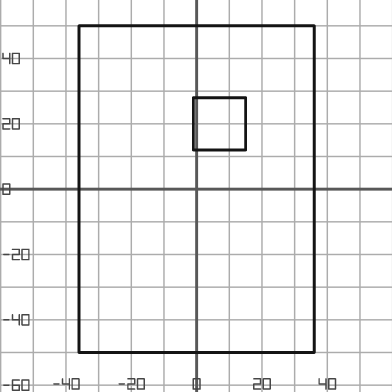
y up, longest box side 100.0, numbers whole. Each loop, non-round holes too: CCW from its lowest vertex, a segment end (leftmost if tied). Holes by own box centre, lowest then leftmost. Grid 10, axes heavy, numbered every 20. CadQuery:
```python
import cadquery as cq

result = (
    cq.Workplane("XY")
    .moveTo(-36.0, -50.0)
    .lineTo(36.0, -50.0)
    .lineTo(36.0, 50.0)
    .lineTo(-36.0, 50.0)
    .close()
    .moveTo(-1.0, 12.0)
    .lineTo(15.0, 12.0)
    .lineTo(15.0, 28.0)
    .lineTo(-1.0, 28.0)
    .close()
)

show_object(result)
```